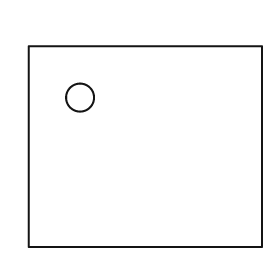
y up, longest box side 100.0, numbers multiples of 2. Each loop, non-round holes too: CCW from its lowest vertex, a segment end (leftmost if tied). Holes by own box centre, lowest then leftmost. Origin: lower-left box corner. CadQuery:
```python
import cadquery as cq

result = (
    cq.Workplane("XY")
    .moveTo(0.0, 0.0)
    .lineTo(100.0, 0.0)
    .lineTo(100.0, 86.0)
    .lineTo(0.0, 86.0)
    .close()
    .moveTo(22.0, 64.0)
    .circle(6.0)
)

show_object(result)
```